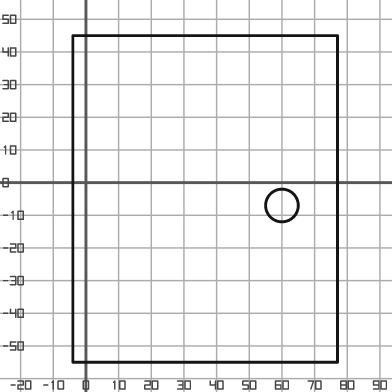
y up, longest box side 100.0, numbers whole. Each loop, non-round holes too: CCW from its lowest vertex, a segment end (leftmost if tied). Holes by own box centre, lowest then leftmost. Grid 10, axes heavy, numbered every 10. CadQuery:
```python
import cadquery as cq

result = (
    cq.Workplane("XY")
    .moveTo(-4.0, -55.0)
    .lineTo(77.0, -55.0)
    .lineTo(77.0, 45.0)
    .lineTo(-4.0, 45.0)
    .close()
    .moveTo(60.0, -7.0)
    .circle(5.0)
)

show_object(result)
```